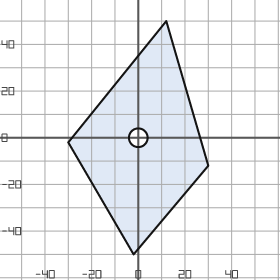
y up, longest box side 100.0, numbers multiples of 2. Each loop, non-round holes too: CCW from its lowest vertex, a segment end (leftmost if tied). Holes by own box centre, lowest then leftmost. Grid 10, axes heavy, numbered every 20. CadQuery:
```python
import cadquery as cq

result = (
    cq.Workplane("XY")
    .moveTo(-2.0, -50.0)
    .lineTo(30.0, -12.0)
    .lineTo(12.0, 50.0)
    .lineTo(-30.0, -2.0)
    .close()
    .moveTo(0.0, 0.0)
    .circle(4.0)
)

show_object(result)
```